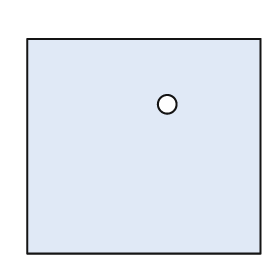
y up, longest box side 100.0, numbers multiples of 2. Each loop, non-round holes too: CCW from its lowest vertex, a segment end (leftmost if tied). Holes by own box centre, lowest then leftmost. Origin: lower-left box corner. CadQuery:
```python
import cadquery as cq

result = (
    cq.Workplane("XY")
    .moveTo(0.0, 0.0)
    .lineTo(100.0, 0.0)
    .lineTo(100.0, 92.0)
    .lineTo(0.0, 92.0)
    .close()
    .moveTo(60.0, 64.0)
    .circle(4.0)
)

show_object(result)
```